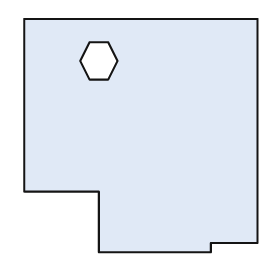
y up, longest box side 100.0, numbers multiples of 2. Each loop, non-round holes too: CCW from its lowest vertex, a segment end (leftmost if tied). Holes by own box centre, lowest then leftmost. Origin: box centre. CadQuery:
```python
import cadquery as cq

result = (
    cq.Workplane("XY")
    .moveTo(-18.0, -50.0)
    .lineTo(30.0, -50.0)
    .lineTo(30.0, -46.0)
    .lineTo(50.0, -46.0)
    .lineTo(50.0, 50.0)
    .lineTo(-50.0, 50.0)
    .lineTo(-50.0, -24.0)
    .lineTo(-18.0, -24.0)
    .close()
    .moveTo(-22.0, 24.0)
    .lineTo(-14.0, 24.0)
    .lineTo(-10.0, 32.0)
    .lineTo(-14.0, 40.0)
    .lineTo(-22.0, 40.0)
    .lineTo(-26.0, 32.0)
    .close()
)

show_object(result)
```